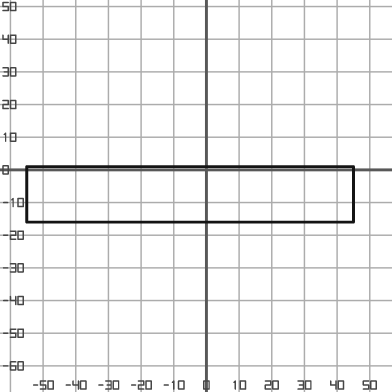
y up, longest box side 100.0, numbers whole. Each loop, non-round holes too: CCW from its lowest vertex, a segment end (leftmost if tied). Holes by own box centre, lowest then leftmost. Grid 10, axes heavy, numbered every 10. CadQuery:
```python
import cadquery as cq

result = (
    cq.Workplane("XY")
    .moveTo(-55.0, -16.0)
    .lineTo(45.0, -16.0)
    .lineTo(45.0, 1.0)
    .lineTo(-55.0, 1.0)
    .close()
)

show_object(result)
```